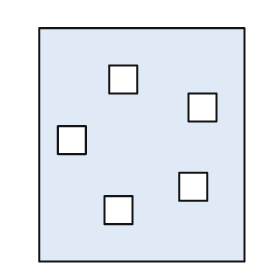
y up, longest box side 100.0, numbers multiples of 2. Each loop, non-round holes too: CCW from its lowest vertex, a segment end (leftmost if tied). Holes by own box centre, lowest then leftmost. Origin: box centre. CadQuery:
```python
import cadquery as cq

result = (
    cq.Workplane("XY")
    .moveTo(-44.0, -50.0)
    .lineTo(44.0, -50.0)
    .lineTo(44.0, 50.0)
    .lineTo(-44.0, 50.0)
    .close()
    .moveTo(-16.0, -34.0)
    .lineTo(-4.0, -34.0)
    .lineTo(-4.0, -22.0)
    .lineTo(-16.0, -22.0)
    .close()
    .moveTo(16.0, -24.0)
    .lineTo(28.0, -24.0)
    .lineTo(28.0, -12.0)
    .lineTo(16.0, -12.0)
    .close()
    .moveTo(-36.0, -4.0)
    .lineTo(-24.0, -4.0)
    .lineTo(-24.0, 8.0)
    .lineTo(-36.0, 8.0)
    .close()
    .moveTo(20.0, 10.0)
    .lineTo(32.0, 10.0)
    .lineTo(32.0, 22.0)
    .lineTo(20.0, 22.0)
    .close()
    .moveTo(-14.0, 22.0)
    .lineTo(-2.0, 22.0)
    .lineTo(-2.0, 34.0)
    .lineTo(-14.0, 34.0)
    .close()
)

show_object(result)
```